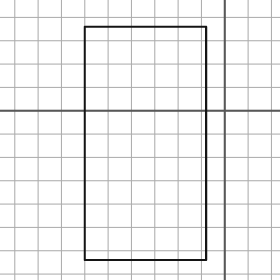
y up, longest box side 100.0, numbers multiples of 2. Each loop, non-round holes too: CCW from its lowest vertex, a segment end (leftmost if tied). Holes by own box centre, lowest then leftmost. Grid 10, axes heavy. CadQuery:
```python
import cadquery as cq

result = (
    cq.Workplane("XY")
    .moveTo(-60.0, -64.0)
    .lineTo(-8.0, -64.0)
    .lineTo(-8.0, 36.0)
    .lineTo(-60.0, 36.0)
    .close()
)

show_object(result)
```